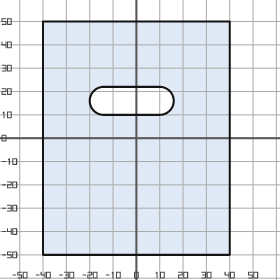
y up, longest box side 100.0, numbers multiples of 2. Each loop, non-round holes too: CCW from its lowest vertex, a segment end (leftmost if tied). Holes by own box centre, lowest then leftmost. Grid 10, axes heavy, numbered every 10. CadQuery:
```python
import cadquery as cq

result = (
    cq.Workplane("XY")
    .moveTo(-40.0, -50.0)
    .lineTo(40.0, -50.0)
    .lineTo(40.0, 50.0)
    .lineTo(-40.0, 50.0)
    .close()
    .moveTo(-14.0, 10.0)
    .lineTo(10.0, 10.0)
    .threePointArc((16.0, 16.0), (10.0, 22.0))
    .lineTo(-14.0, 22.0)
    .threePointArc((-20.0, 16.0), (-14.0, 10.0))
    .close()
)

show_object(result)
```